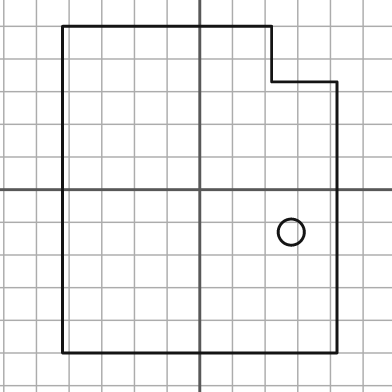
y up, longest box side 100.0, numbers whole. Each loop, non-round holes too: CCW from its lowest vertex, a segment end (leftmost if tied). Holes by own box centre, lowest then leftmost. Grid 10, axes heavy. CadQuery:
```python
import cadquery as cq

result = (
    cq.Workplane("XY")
    .moveTo(-42.0, -50.0)
    .lineTo(42.0, -50.0)
    .lineTo(42.0, 33.0)
    .lineTo(22.0, 33.0)
    .lineTo(22.0, 50.0)
    .lineTo(-42.0, 50.0)
    .close()
    .moveTo(28.0, -13.0)
    .circle(4.0)
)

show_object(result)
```